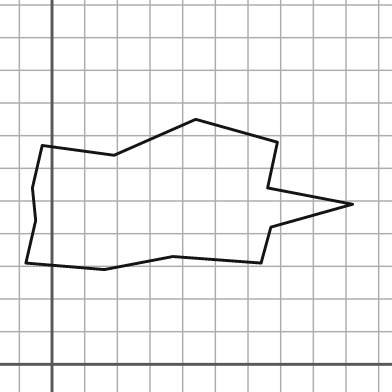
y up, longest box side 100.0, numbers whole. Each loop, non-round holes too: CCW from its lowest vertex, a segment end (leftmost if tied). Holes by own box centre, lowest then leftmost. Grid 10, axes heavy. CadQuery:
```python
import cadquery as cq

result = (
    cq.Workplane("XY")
    .moveTo(16.0, 29.0)
    .lineTo(37.0, 33.0)
    .lineTo(64.0, 31.0)
    .lineTo(67.0, 42.0)
    .lineTo(92.0, 49.0)
    .lineTo(66.0, 54.0)
    .lineTo(69.0, 68.0)
    .lineTo(44.0, 75.0)
    .lineTo(19.0, 64.0)
    .lineTo(-3.0, 67.0)
    .lineTo(-6.0, 54.0)
    .lineTo(-5.0, 44.0)
    .lineTo(-8.0, 31.0)
    .close()
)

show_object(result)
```